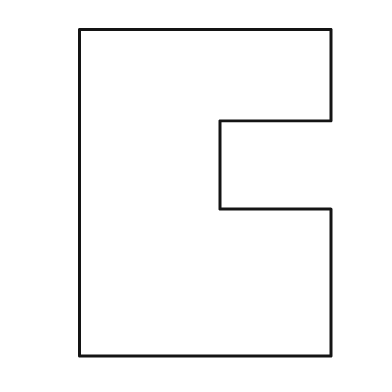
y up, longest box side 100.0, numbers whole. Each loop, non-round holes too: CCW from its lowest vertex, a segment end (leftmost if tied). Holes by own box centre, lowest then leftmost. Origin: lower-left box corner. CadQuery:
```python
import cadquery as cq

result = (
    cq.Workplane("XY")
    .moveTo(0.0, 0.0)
    .lineTo(77.0, 0.0)
    .lineTo(77.0, 45.0)
    .lineTo(43.0, 45.0)
    .lineTo(43.0, 72.0)
    .lineTo(77.0, 72.0)
    .lineTo(77.0, 100.0)
    .lineTo(0.0, 100.0)
    .close()
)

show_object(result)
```